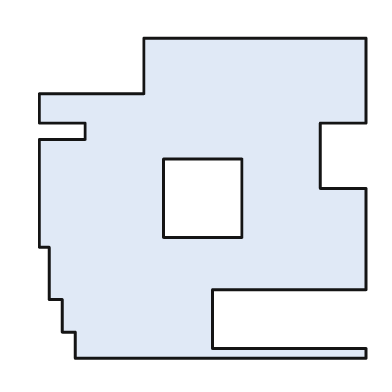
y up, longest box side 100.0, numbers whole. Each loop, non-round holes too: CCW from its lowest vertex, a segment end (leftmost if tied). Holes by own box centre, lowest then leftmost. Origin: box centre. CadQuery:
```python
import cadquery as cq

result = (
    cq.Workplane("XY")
    .moveTo(-39.0, -49.0)
    .lineTo(50.0, -49.0)
    .lineTo(50.0, -46.0)
    .lineTo(3.0, -46.0)
    .lineTo(3.0, -28.0)
    .lineTo(50.0, -28.0)
    .lineTo(50.0, 3.0)
    .lineTo(36.0, 3.0)
    .lineTo(36.0, 23.0)
    .lineTo(50.0, 23.0)
    .lineTo(50.0, 49.0)
    .lineTo(-18.0, 49.0)
    .lineTo(-18.0, 32.0)
    .lineTo(-50.0, 32.0)
    .lineTo(-50.0, 23.0)
    .lineTo(-36.0, 23.0)
    .lineTo(-36.0, 18.0)
    .lineTo(-50.0, 18.0)
    .lineTo(-50.0, -15.0)
    .lineTo(-47.0, -15.0)
    .lineTo(-47.0, -31.0)
    .lineTo(-43.0, -31.0)
    .lineTo(-43.0, -41.0)
    .lineTo(-39.0, -41.0)
    .close()
    .moveTo(-12.0, -12.0)
    .lineTo(12.0, -12.0)
    .lineTo(12.0, 12.0)
    .lineTo(-12.0, 12.0)
    .close()
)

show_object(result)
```